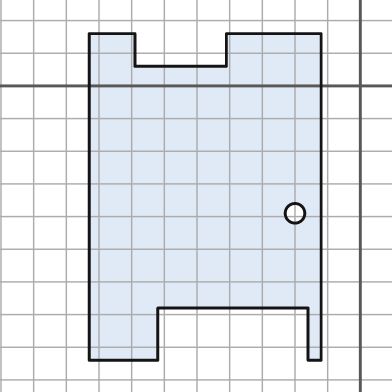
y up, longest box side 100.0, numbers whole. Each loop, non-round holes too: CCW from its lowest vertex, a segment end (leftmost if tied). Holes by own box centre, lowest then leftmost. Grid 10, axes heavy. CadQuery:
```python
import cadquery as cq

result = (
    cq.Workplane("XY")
    .moveTo(-83.0, -84.0)
    .lineTo(-62.0, -84.0)
    .lineTo(-62.0, -68.0)
    .lineTo(-16.0, -68.0)
    .lineTo(-16.0, -84.0)
    .lineTo(-12.0, -84.0)
    .lineTo(-12.0, 16.0)
    .lineTo(-41.0, 16.0)
    .lineTo(-41.0, 6.0)
    .lineTo(-69.0, 6.0)
    .lineTo(-69.0, 16.0)
    .lineTo(-83.0, 16.0)
    .close()
    .moveTo(-20.0, -39.0)
    .circle(3.0)
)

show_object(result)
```